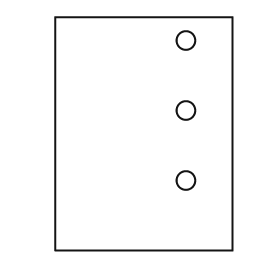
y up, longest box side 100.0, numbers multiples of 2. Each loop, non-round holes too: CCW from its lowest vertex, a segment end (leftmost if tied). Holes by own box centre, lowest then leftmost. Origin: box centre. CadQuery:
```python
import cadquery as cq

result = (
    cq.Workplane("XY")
    .moveTo(-38.0, -50.0)
    .lineTo(38.0, -50.0)
    .lineTo(38.0, 50.0)
    .lineTo(-38.0, 50.0)
    .close()
    .moveTo(18.0, -20.0)
    .circle(4.0)
    .moveTo(18.0, 10.0)
    .circle(4.0)
    .moveTo(18.0, 40.0)
    .circle(4.0)
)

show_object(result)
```